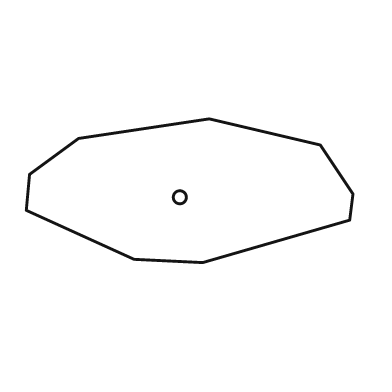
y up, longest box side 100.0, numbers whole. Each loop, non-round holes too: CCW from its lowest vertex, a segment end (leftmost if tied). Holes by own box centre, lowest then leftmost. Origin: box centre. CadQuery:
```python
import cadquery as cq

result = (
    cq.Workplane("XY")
    .moveTo(4.0, -22.0)
    .lineTo(49.0, -9.0)
    .lineTo(50.0, -1.0)
    .lineTo(40.0, 14.0)
    .lineTo(6.0, 22.0)
    .lineTo(-34.0, 16.0)
    .lineTo(-49.0, 5.0)
    .lineTo(-50.0, -6.0)
    .lineTo(-17.0, -21.0)
    .close()
    .moveTo(-3.0, -2.0)
    .circle(2.0)
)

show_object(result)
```